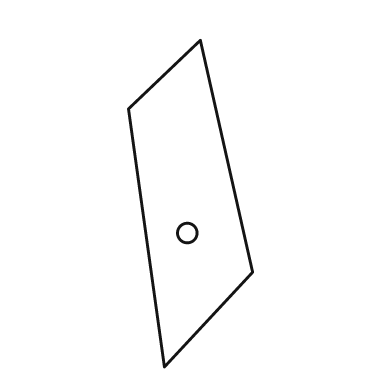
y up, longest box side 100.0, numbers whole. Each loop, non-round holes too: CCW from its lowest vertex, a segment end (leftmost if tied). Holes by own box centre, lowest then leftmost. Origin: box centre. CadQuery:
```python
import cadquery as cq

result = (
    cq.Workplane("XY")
    .moveTo(-8.0, -50.0)
    .lineTo(19.0, -21.0)
    .lineTo(3.0, 50.0)
    .lineTo(-19.0, 29.0)
    .close()
    .moveTo(-1.0, -9.0)
    .circle(3.0)
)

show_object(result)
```